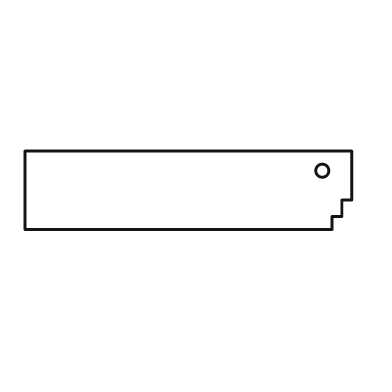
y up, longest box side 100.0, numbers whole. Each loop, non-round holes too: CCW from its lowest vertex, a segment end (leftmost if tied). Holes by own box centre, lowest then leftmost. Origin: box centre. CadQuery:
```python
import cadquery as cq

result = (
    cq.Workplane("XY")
    .moveTo(-50.0, -12.0)
    .lineTo(44.0, -12.0)
    .lineTo(44.0, -8.0)
    .lineTo(47.0, -8.0)
    .lineTo(47.0, -3.0)
    .lineTo(50.0, -3.0)
    .lineTo(50.0, 12.0)
    .lineTo(-50.0, 12.0)
    .close()
    .moveTo(41.0, 6.0)
    .circle(2.0)
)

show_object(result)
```